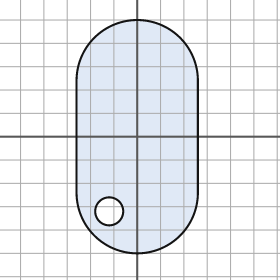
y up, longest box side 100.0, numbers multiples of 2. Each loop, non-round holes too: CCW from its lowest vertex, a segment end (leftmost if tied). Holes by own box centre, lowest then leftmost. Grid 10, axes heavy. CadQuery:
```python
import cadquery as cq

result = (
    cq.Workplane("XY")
    .moveTo(-26.0, -24.0)
    .threePointArc((0.0, -50.0), (26.0, -24.0))
    .lineTo(26.0, 24.0)
    .threePointArc((0.0, 50.0), (-26.0, 24.0))
    .close()
    .moveTo(-12.0, -32.0)
    .circle(6.0)
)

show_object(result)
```